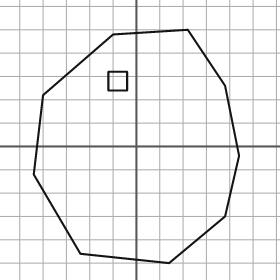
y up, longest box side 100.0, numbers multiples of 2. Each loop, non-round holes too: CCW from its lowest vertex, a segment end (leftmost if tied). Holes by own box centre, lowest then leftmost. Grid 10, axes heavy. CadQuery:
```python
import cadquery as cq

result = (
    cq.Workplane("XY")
    .moveTo(14.0, -50.0)
    .lineTo(38.0, -30.0)
    .lineTo(44.0, -4.0)
    .lineTo(38.0, 26.0)
    .lineTo(22.0, 50.0)
    .lineTo(-10.0, 48.0)
    .lineTo(-40.0, 22.0)
    .lineTo(-44.0, -12.0)
    .lineTo(-24.0, -46.0)
    .close()
    .moveTo(-12.0, 24.0)
    .lineTo(-4.0, 24.0)
    .lineTo(-4.0, 32.0)
    .lineTo(-12.0, 32.0)
    .close()
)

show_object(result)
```